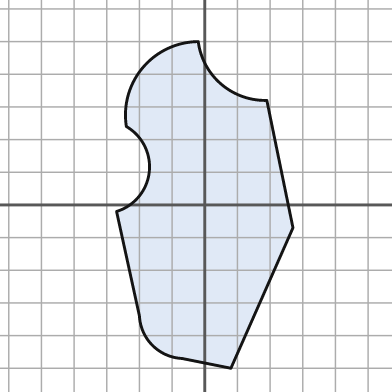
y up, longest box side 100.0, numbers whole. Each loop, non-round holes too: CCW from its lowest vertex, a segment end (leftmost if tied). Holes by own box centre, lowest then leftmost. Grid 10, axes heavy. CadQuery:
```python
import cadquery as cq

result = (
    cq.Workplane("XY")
    .moveTo(8.0, -50.0)
    .lineTo(27.0, -7.0)
    .lineTo(19.0, 32.0)
    .threePointArc((5.0, 37.0), (-2.0, 50.0))
    .threePointArc((-19.0, 42.0), (-24.0, 24.0))
    .threePointArc((-17.0, 10.0), (-27.0, -2.0))
    .lineTo(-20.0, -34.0)
    .threePointArc((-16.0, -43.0), (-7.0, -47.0))
    .close()
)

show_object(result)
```